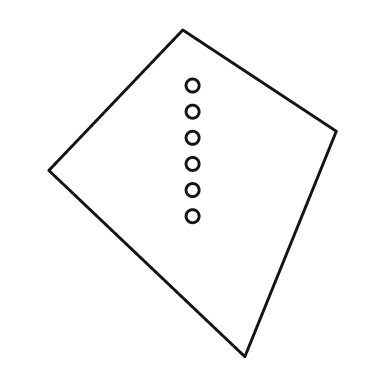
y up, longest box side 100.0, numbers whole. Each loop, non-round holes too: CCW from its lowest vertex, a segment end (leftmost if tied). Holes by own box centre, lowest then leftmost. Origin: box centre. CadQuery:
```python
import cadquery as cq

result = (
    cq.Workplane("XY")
    .moveTo(16.0, -50.0)
    .lineTo(44.0, 19.0)
    .lineTo(-3.0, 50.0)
    .lineTo(-44.0, 7.0)
    .close()
    .moveTo(0.0, -7.0)
    .circle(2.0)
    .moveTo(0.0, 1.0)
    .circle(2.0)
    .moveTo(0.0, 9.0)
    .circle(2.0)
    .moveTo(0.0, 17.0)
    .circle(2.0)
    .moveTo(0.0, 25.0)
    .circle(2.0)
    .moveTo(0.0, 33.0)
    .circle(2.0)
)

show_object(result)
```